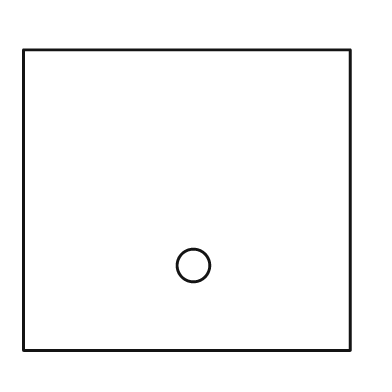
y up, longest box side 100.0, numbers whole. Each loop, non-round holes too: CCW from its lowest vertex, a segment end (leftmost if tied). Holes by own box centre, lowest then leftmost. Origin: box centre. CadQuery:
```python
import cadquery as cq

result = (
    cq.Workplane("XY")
    .moveTo(-50.0, -46.0)
    .lineTo(50.0, -46.0)
    .lineTo(50.0, 46.0)
    .lineTo(-50.0, 46.0)
    .close()
    .moveTo(2.0, -20.0)
    .circle(5.0)
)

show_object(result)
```